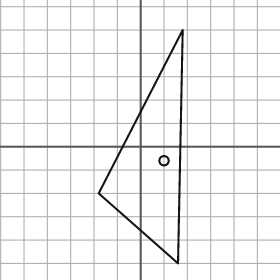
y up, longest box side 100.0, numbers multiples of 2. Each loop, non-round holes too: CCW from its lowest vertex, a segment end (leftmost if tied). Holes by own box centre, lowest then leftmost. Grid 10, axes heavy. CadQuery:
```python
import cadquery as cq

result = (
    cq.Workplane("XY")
    .moveTo(16.0, -50.0)
    .lineTo(18.0, 50.0)
    .lineTo(-18.0, -20.0)
    .close()
    .moveTo(10.0, -6.0)
    .circle(2.0)
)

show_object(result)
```